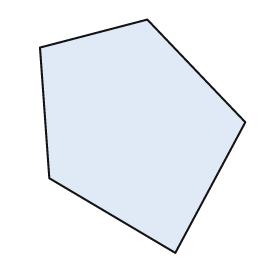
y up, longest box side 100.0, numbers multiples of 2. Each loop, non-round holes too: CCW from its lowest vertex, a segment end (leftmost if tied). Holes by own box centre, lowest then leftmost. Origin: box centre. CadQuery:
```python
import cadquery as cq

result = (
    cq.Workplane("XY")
    .moveTo(14.0, -50.0)
    .lineTo(44.0, 6.0)
    .lineTo(2.0, 50.0)
    .lineTo(-44.0, 38.0)
    .lineTo(-40.0, -18.0)
    .close()
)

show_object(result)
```